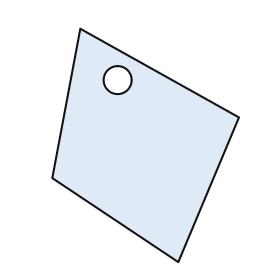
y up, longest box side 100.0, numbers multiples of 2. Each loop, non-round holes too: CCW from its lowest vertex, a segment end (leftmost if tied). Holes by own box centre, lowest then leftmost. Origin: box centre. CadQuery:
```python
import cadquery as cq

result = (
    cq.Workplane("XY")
    .moveTo(14.0, -50.0)
    .lineTo(40.0, 12.0)
    .lineTo(-28.0, 50.0)
    .lineTo(-40.0, -14.0)
    .close()
    .moveTo(-12.0, 28.0)
    .circle(6.0)
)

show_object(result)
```